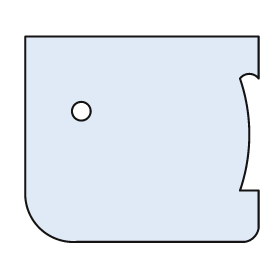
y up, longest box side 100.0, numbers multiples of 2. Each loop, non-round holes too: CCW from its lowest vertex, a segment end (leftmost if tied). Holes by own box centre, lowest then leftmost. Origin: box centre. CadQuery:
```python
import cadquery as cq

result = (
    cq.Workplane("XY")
    .moveTo(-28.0, -44.0)
    .lineTo(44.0, -44.0)
    .threePointArc((48.0, -42.0), (50.0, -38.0))
    .lineTo(50.0, -22.0)
    .lineTo(42.0, -22.0)
    .threePointArc((46.0, 2.0), (42.0, 26.0))
    .threePointArc((46.0, 28.0), (50.0, 26.0))
    .lineTo(50.0, 44.0)
    .lineTo(-50.0, 44.0)
    .lineTo(-50.0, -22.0)
    .threePointArc((-44.0, -38.0), (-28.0, -44.0))
    .close()
    .moveTo(-26.0, 12.0)
    .circle(4.0)
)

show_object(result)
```